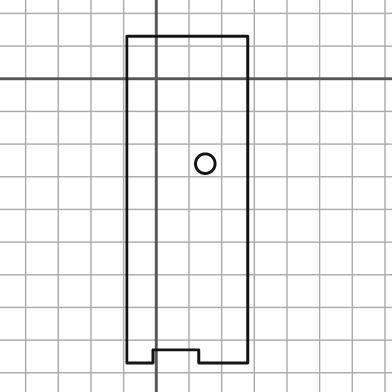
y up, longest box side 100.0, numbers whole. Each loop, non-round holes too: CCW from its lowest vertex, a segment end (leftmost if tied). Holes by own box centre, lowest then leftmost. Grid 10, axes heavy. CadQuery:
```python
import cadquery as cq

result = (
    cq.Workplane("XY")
    .moveTo(-9.0, -87.0)
    .lineTo(-1.0, -87.0)
    .lineTo(-1.0, -83.0)
    .lineTo(13.0, -83.0)
    .lineTo(13.0, -87.0)
    .lineTo(28.0, -87.0)
    .lineTo(28.0, 13.0)
    .lineTo(-9.0, 13.0)
    .close()
    .moveTo(15.0, -26.0)
    .circle(3.0)
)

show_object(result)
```